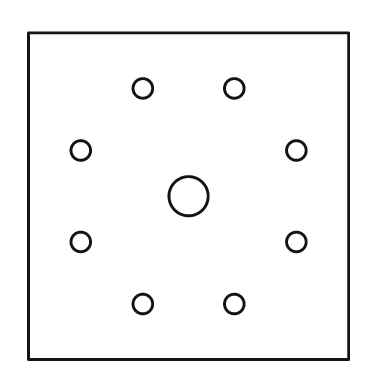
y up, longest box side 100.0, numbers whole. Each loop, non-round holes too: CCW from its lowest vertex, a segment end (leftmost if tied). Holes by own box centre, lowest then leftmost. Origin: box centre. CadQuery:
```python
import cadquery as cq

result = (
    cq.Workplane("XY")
    .moveTo(-49.0, -50.0)
    .lineTo(49.0, -50.0)
    .lineTo(49.0, 50.0)
    .lineTo(-49.0, 50.0)
    .close()
    .moveTo(-14.0, -33.0)
    .circle(3.0)
    .moveTo(14.0, -33.0)
    .circle(3.0)
    .moveTo(-33.0, -14.0)
    .circle(3.0)
    .moveTo(33.0, -14.0)
    .circle(3.0)
    .moveTo(0.0, 0.0)
    .circle(6.0)
    .moveTo(-33.0, 14.0)
    .circle(3.0)
    .moveTo(33.0, 14.0)
    .circle(3.0)
    .moveTo(-14.0, 33.0)
    .circle(3.0)
    .moveTo(14.0, 33.0)
    .circle(3.0)
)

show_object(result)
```